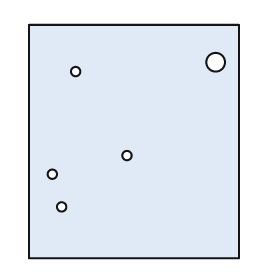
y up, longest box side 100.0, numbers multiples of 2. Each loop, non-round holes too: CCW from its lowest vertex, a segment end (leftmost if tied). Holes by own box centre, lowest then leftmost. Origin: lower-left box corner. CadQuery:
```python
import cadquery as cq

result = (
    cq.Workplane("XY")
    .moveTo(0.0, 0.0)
    .lineTo(90.0, 0.0)
    .lineTo(90.0, 100.0)
    .lineTo(0.0, 100.0)
    .close()
    .moveTo(14.0, 22.0)
    .circle(2.0)
    .moveTo(10.0, 36.0)
    .circle(2.0)
    .moveTo(42.0, 44.0)
    .circle(2.0)
    .moveTo(20.0, 80.0)
    .circle(2.0)
    .moveTo(80.0, 84.0)
    .circle(4.0)
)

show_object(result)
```